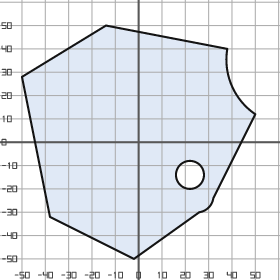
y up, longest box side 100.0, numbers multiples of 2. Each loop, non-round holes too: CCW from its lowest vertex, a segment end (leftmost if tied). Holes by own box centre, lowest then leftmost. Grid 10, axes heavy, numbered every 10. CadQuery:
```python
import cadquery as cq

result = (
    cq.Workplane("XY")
    .moveTo(-2.0, -50.0)
    .lineTo(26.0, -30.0)
    .threePointArc((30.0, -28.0), (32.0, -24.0))
    .lineTo(50.0, 12.0)
    .threePointArc((40.0, 24.0), (38.0, 40.0))
    .lineTo(-14.0, 50.0)
    .lineTo(-50.0, 28.0)
    .lineTo(-38.0, -32.0)
    .close()
    .moveTo(22.0, -14.0)
    .circle(6.0)
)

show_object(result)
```